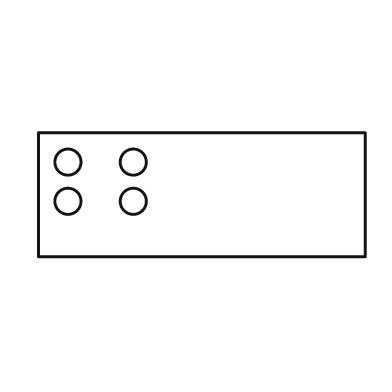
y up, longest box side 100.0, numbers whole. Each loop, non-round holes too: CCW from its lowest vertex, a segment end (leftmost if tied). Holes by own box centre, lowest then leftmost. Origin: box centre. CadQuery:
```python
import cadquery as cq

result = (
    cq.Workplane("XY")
    .moveTo(-50.0, -19.0)
    .lineTo(50.0, -19.0)
    .lineTo(50.0, 19.0)
    .lineTo(-50.0, 19.0)
    .close()
    .moveTo(-41.0, -2.0)
    .circle(4.0)
    .moveTo(-21.0, -2.0)
    .circle(4.0)
    .moveTo(-41.0, 10.0)
    .circle(4.0)
    .moveTo(-21.0, 10.0)
    .circle(4.0)
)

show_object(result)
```